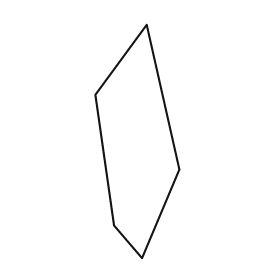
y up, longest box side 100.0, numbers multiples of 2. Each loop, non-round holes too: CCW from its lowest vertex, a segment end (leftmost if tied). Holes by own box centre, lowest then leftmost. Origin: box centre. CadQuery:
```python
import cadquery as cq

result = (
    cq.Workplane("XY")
    .moveTo(2.0, -50.0)
    .lineTo(18.0, -12.0)
    .lineTo(4.0, 50.0)
    .lineTo(-18.0, 20.0)
    .lineTo(-10.0, -36.0)
    .close()
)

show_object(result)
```